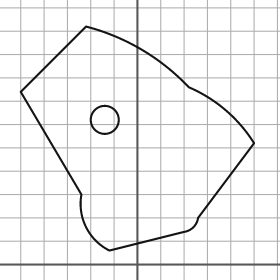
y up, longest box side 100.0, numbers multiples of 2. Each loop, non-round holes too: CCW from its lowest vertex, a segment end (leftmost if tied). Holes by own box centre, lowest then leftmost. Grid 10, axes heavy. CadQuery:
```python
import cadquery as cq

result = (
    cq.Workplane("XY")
    .moveTo(-12.0, 6.0)
    .lineTo(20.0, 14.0)
    .threePointArc((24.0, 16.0), (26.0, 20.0))
    .lineTo(50.0, 52.0)
    .threePointArc((38.0, 66.0), (22.0, 76.0))
    .threePointArc((2.0, 92.0), (-22.0, 102.0))
    .lineTo(-50.0, 74.0)
    .lineTo(-24.0, 30.0)
    .threePointArc((-22.0, 16.0), (-12.0, 6.0))
    .close()
    .moveTo(-14.0, 62.0)
    .circle(6.0)
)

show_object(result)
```